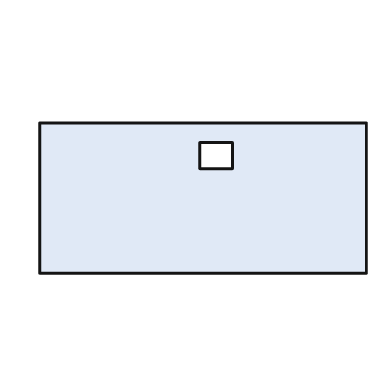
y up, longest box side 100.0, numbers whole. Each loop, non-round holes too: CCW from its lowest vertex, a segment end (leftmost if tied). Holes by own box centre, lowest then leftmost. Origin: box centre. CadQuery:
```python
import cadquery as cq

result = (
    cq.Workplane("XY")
    .moveTo(-50.0, -23.0)
    .lineTo(50.0, -23.0)
    .lineTo(50.0, 23.0)
    .lineTo(-50.0, 23.0)
    .close()
    .moveTo(-1.0, 9.0)
    .lineTo(9.0, 9.0)
    .lineTo(9.0, 17.0)
    .lineTo(-1.0, 17.0)
    .close()
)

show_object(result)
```